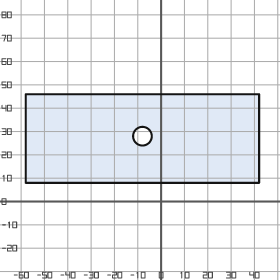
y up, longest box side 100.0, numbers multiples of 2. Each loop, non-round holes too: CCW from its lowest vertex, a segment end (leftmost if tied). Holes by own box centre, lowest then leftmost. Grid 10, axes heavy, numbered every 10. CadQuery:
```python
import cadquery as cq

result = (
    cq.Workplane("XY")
    .moveTo(-58.0, 8.0)
    .lineTo(42.0, 8.0)
    .lineTo(42.0, 46.0)
    .lineTo(-58.0, 46.0)
    .close()
    .moveTo(-8.0, 28.0)
    .circle(4.0)
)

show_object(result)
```